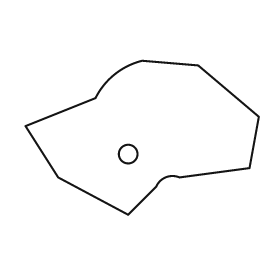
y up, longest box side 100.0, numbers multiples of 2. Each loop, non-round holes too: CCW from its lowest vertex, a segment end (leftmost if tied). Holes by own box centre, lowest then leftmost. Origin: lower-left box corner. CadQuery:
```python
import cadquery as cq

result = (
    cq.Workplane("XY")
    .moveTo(44.0, 0.0)
    .lineTo(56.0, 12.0)
    .threePointArc((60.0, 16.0), (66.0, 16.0))
    .lineTo(96.0, 20.0)
    .lineTo(100.0, 42.0)
    .lineTo(74.0, 64.0)
    .lineTo(50.0, 66.0)
    .threePointArc((38.0, 60.0), (30.0, 50.0))
    .lineTo(0.0, 38.0)
    .lineTo(14.0, 16.0)
    .close()
    .moveTo(44.0, 26.0)
    .circle(4.0)
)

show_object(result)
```